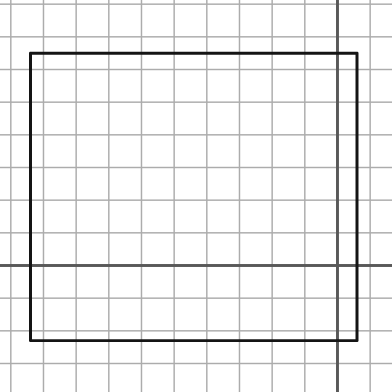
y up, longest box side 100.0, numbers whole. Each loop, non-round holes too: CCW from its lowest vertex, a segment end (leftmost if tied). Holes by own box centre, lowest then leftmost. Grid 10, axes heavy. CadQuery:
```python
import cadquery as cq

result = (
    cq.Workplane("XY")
    .moveTo(-94.0, -23.0)
    .lineTo(6.0, -23.0)
    .lineTo(6.0, 65.0)
    .lineTo(-94.0, 65.0)
    .close()
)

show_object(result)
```